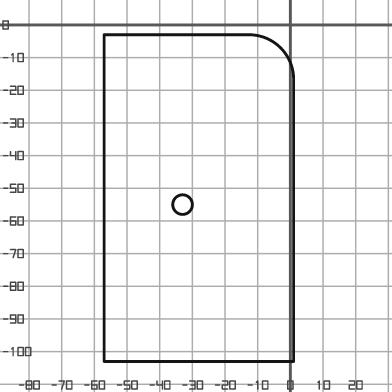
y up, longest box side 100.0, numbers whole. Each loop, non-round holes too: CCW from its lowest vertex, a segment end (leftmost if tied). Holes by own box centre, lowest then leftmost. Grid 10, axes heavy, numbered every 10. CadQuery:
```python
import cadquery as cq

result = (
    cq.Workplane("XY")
    .moveTo(-57.0, -103.0)
    .lineTo(1.0, -103.0)
    .lineTo(1.0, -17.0)
    .threePointArc((-3.0, -7.0), (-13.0, -3.0))
    .lineTo(-57.0, -3.0)
    .close()
    .moveTo(-33.0, -55.0)
    .circle(3.0)
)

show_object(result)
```